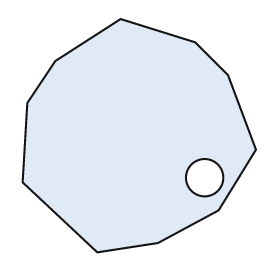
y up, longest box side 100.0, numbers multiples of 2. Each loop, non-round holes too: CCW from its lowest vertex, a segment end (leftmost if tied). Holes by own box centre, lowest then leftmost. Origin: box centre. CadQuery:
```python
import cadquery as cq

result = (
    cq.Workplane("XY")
    .moveTo(-18.0, -50.0)
    .lineTo(8.0, -46.0)
    .lineTo(34.0, -32.0)
    .lineTo(50.0, -6.0)
    .lineTo(38.0, 26.0)
    .lineTo(24.0, 40.0)
    .lineTo(-8.0, 50.0)
    .lineTo(-36.0, 32.0)
    .lineTo(-48.0, 14.0)
    .lineTo(-50.0, -20.0)
    .close()
    .moveTo(28.0, -18.0)
    .circle(8.0)
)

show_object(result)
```